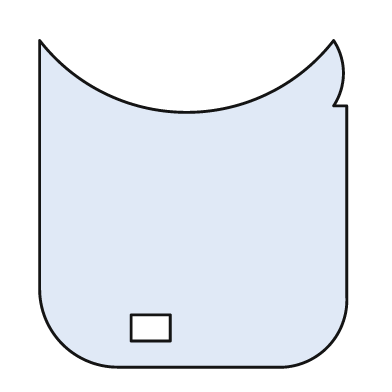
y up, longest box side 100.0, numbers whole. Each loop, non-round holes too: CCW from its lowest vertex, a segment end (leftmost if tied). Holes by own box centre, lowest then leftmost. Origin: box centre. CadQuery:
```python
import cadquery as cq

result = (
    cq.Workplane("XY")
    .moveTo(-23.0, -50.0)
    .lineTo(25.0, -50.0)
    .threePointArc((41.0, -44.0), (47.0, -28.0))
    .lineTo(47.0, 30.0)
    .lineTo(43.0, 30.0)
    .threePointArc((46.0, 40.0), (43.0, 50.0))
    .threePointArc((-2.0, 28.0), (-47.0, 50.0))
    .lineTo(-47.0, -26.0)
    .threePointArc((-40.0, -43.0), (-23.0, -50.0))
    .close()
    .moveTo(-19.0, -42.0)
    .lineTo(-7.0, -42.0)
    .lineTo(-7.0, -34.0)
    .lineTo(-19.0, -34.0)
    .close()
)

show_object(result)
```